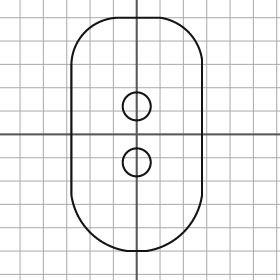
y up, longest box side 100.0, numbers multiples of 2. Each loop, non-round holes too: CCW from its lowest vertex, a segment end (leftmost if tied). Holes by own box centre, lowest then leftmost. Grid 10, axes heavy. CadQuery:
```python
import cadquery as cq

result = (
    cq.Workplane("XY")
    .moveTo(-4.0, -50.0)
    .lineTo(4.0, -50.0)
    .threePointArc((20.0, -42.0), (28.0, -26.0))
    .lineTo(28.0, 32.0)
    .threePointArc((22.0, 44.0), (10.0, 50.0))
    .lineTo(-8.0, 50.0)
    .threePointArc((-22.0, 44.0), (-28.0, 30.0))
    .lineTo(-28.0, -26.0)
    .threePointArc((-20.0, -42.0), (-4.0, -50.0))
    .close()
    .moveTo(0.0, -12.0)
    .circle(6.0)
    .moveTo(0.0, 12.0)
    .circle(6.0)
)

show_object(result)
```